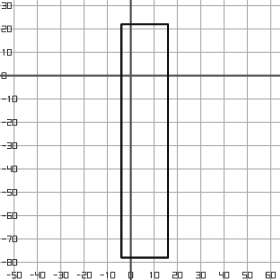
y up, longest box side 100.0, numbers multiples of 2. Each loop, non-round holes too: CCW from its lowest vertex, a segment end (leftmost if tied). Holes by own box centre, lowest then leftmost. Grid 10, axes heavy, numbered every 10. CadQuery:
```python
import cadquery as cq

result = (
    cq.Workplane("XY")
    .moveTo(-4.0, -78.0)
    .lineTo(16.0, -78.0)
    .lineTo(16.0, 22.0)
    .lineTo(-4.0, 22.0)
    .close()
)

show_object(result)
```